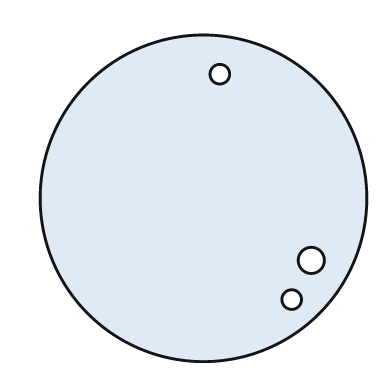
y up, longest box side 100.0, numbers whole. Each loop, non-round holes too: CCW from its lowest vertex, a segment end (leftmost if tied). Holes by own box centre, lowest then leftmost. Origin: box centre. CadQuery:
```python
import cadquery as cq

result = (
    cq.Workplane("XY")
    .moveTo(0.0, 0.0)
    .circle(50.0)
    .moveTo(27.0, -31.0)
    .circle(3.0)
    .moveTo(33.0, -19.0)
    .circle(4.0)
    .moveTo(5.0, 38.0)
    .circle(3.0)
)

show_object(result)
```